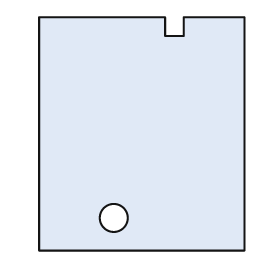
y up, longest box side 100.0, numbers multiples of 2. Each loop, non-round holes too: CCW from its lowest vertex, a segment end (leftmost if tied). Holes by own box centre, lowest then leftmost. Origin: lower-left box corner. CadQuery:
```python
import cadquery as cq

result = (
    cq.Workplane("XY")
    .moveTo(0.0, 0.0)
    .lineTo(88.0, 0.0)
    .lineTo(88.0, 100.0)
    .lineTo(62.0, 100.0)
    .lineTo(62.0, 92.0)
    .lineTo(54.0, 92.0)
    .lineTo(54.0, 100.0)
    .lineTo(0.0, 100.0)
    .close()
    .moveTo(32.0, 14.0)
    .circle(6.0)
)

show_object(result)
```